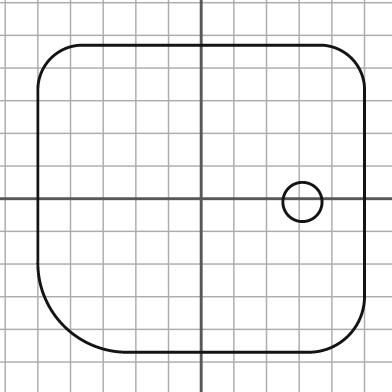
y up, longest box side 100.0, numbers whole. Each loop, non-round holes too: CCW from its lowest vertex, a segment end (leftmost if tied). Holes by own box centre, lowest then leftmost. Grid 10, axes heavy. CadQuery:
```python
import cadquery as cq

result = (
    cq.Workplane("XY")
    .moveTo(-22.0, -47.0)
    .lineTo(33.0, -47.0)
    .threePointArc((45.0, -42.0), (50.0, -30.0))
    .lineTo(50.0, 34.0)
    .threePointArc((46.0, 43.0), (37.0, 47.0))
    .lineTo(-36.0, 47.0)
    .threePointArc((-46.0, 43.0), (-50.0, 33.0))
    .lineTo(-50.0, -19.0)
    .threePointArc((-42.0, -39.0), (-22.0, -47.0))
    .close()
    .moveTo(31.0, -1.0)
    .circle(6.0)
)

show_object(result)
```